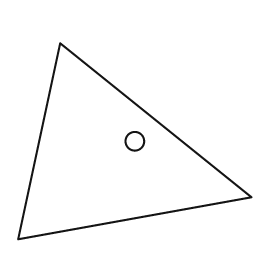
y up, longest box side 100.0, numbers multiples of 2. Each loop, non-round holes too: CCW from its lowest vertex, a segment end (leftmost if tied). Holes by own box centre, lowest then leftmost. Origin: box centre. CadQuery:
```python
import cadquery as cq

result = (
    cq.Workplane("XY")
    .moveTo(-50.0, -42.0)
    .lineTo(50.0, -24.0)
    .lineTo(-32.0, 42.0)
    .close()
    .moveTo(0.0, 0.0)
    .circle(4.0)
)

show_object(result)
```